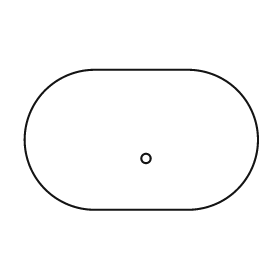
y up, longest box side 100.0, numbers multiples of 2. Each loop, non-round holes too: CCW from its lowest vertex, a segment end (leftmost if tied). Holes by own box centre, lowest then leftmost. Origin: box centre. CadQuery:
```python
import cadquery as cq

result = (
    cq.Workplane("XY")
    .moveTo(-20.0, -30.0)
    .lineTo(20.0, -30.0)
    .threePointArc((50.0, 0.0), (20.0, 30.0))
    .lineTo(-20.0, 30.0)
    .threePointArc((-50.0, 0.0), (-20.0, -30.0))
    .close()
    .moveTo(2.0, -8.0)
    .circle(2.0)
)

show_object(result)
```